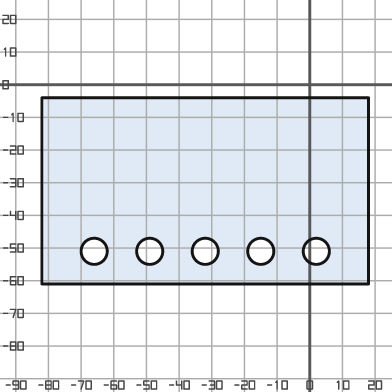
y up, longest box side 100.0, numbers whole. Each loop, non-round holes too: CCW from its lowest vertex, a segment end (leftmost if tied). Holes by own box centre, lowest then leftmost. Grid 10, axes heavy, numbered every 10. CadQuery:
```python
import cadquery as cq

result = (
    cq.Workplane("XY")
    .moveTo(-82.0, -61.0)
    .lineTo(18.0, -61.0)
    .lineTo(18.0, -4.0)
    .lineTo(-82.0, -4.0)
    .close()
    .moveTo(-66.0, -51.0)
    .circle(4.0)
    .moveTo(-49.0, -51.0)
    .circle(4.0)
    .moveTo(-32.0, -51.0)
    .circle(4.0)
    .moveTo(-15.0, -51.0)
    .circle(4.0)
    .moveTo(2.0, -51.0)
    .circle(4.0)
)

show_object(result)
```